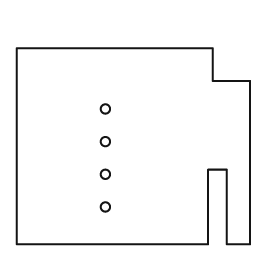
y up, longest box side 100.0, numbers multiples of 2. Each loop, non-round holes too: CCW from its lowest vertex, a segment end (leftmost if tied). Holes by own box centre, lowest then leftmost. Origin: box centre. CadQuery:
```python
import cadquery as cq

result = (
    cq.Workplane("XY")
    .moveTo(-50.0, -42.0)
    .lineTo(32.0, -42.0)
    .lineTo(32.0, -10.0)
    .lineTo(40.0, -10.0)
    .lineTo(40.0, -42.0)
    .lineTo(50.0, -42.0)
    .lineTo(50.0, 28.0)
    .lineTo(34.0, 28.0)
    .lineTo(34.0, 42.0)
    .lineTo(-50.0, 42.0)
    .close()
    .moveTo(-12.0, -26.0)
    .circle(2.0)
    .moveTo(-12.0, -12.0)
    .circle(2.0)
    .moveTo(-12.0, 2.0)
    .circle(2.0)
    .moveTo(-12.0, 16.0)
    .circle(2.0)
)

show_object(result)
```